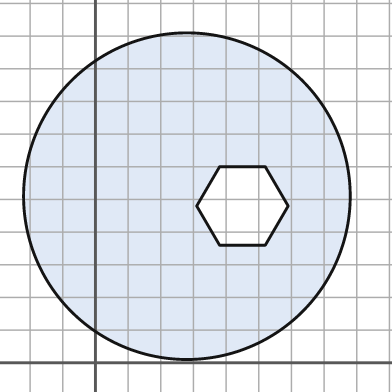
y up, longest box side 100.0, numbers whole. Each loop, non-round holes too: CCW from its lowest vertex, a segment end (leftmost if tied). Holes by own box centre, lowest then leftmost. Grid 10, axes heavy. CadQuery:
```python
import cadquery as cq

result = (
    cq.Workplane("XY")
    .moveTo(28.0, 51.0)
    .circle(50.0)
    .moveTo(38.0, 36.0)
    .lineTo(52.0, 36.0)
    .lineTo(59.0, 48.0)
    .lineTo(52.0, 60.0)
    .lineTo(38.0, 60.0)
    .lineTo(31.0, 48.0)
    .close()
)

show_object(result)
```